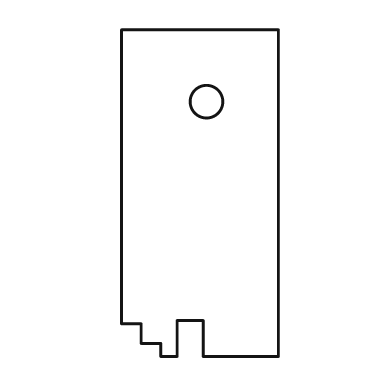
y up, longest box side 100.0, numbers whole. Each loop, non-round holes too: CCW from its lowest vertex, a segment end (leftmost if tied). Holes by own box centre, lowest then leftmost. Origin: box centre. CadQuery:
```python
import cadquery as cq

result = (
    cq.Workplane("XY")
    .moveTo(-12.0, -50.0)
    .lineTo(-7.0, -50.0)
    .lineTo(-7.0, -39.0)
    .lineTo(1.0, -39.0)
    .lineTo(1.0, -50.0)
    .lineTo(24.0, -50.0)
    .lineTo(24.0, 50.0)
    .lineTo(-24.0, 50.0)
    .lineTo(-24.0, -40.0)
    .lineTo(-18.0, -40.0)
    .lineTo(-18.0, -46.0)
    .lineTo(-12.0, -46.0)
    .close()
    .moveTo(2.0, 28.0)
    .circle(5.0)
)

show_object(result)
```